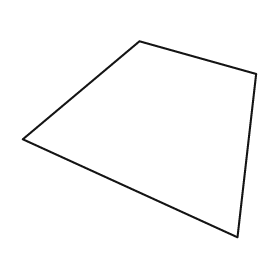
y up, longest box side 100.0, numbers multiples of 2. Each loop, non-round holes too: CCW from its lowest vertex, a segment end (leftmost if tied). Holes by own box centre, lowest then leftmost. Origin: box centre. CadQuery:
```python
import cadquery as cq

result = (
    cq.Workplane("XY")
    .moveTo(42.0, -42.0)
    .lineTo(50.0, 28.0)
    .lineTo(0.0, 42.0)
    .lineTo(-50.0, 0.0)
    .close()
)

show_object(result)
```